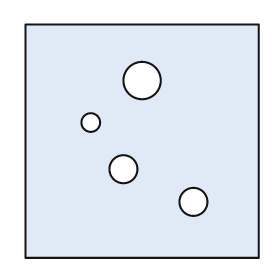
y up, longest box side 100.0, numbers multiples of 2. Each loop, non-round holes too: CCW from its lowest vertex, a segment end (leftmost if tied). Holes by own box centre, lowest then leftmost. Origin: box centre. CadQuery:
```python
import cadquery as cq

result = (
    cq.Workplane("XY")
    .moveTo(-50.0, -50.0)
    .lineTo(50.0, -50.0)
    .lineTo(50.0, 50.0)
    .lineTo(-50.0, 50.0)
    .close()
    .moveTo(22.0, -26.0)
    .circle(6.0)
    .moveTo(-8.0, -12.0)
    .circle(6.0)
    .moveTo(-22.0, 8.0)
    .circle(4.0)
    .moveTo(0.0, 26.0)
    .circle(8.0)
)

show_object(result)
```